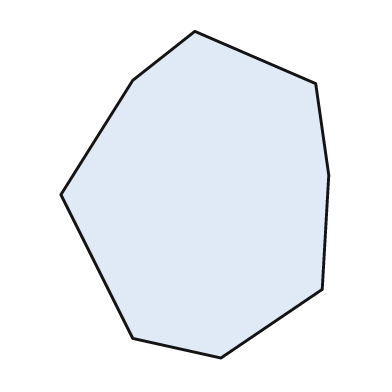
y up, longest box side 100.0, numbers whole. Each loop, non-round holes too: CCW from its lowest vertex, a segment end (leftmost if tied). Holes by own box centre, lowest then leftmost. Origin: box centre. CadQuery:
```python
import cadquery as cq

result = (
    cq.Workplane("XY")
    .moveTo(8.0, -50.0)
    .lineTo(39.0, -29.0)
    .lineTo(41.0, 6.0)
    .lineTo(37.0, 34.0)
    .lineTo(0.0, 50.0)
    .lineTo(-19.0, 35.0)
    .lineTo(-41.0, 0.0)
    .lineTo(-19.0, -44.0)
    .close()
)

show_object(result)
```